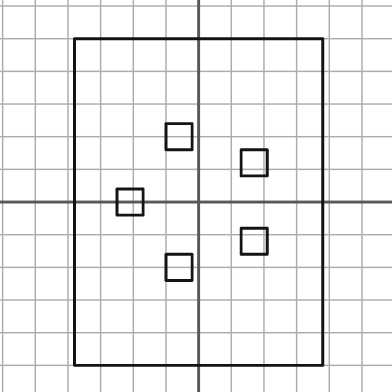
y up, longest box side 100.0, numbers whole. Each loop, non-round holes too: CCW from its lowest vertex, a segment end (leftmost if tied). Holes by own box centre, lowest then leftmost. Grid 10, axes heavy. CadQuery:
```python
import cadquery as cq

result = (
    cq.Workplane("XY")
    .moveTo(-38.0, -50.0)
    .lineTo(38.0, -50.0)
    .lineTo(38.0, 50.0)
    .lineTo(-38.0, 50.0)
    .close()
    .moveTo(-10.0, -24.0)
    .lineTo(-2.0, -24.0)
    .lineTo(-2.0, -16.0)
    .lineTo(-10.0, -16.0)
    .close()
    .moveTo(13.0, -16.0)
    .lineTo(21.0, -16.0)
    .lineTo(21.0, -8.0)
    .lineTo(13.0, -8.0)
    .close()
    .moveTo(-25.0, -4.0)
    .lineTo(-17.0, -4.0)
    .lineTo(-17.0, 4.0)
    .lineTo(-25.0, 4.0)
    .close()
    .moveTo(13.0, 8.0)
    .lineTo(21.0, 8.0)
    .lineTo(21.0, 16.0)
    .lineTo(13.0, 16.0)
    .close()
    .moveTo(-10.0, 16.0)
    .lineTo(-2.0, 16.0)
    .lineTo(-2.0, 24.0)
    .lineTo(-10.0, 24.0)
    .close()
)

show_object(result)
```